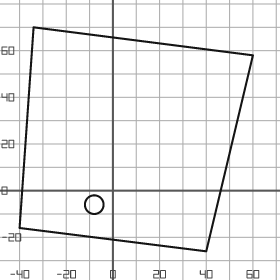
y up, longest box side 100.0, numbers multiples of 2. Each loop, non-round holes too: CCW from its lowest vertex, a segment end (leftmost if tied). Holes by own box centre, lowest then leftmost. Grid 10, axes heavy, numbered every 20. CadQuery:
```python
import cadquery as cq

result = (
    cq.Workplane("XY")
    .moveTo(40.0, -26.0)
    .lineTo(60.0, 58.0)
    .lineTo(-34.0, 70.0)
    .lineTo(-40.0, -16.0)
    .close()
    .moveTo(-8.0, -6.0)
    .circle(4.0)
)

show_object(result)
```